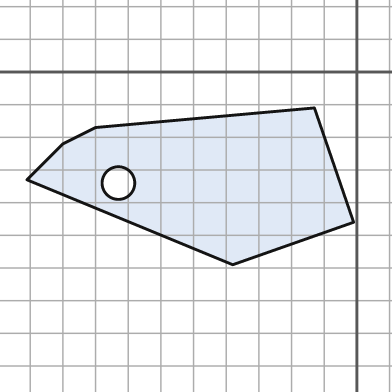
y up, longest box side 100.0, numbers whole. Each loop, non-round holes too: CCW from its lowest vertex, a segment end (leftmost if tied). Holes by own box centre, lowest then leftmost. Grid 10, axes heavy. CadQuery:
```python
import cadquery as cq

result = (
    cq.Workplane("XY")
    .moveTo(-38.0, -59.0)
    .lineTo(-1.0, -46.0)
    .lineTo(-13.0, -11.0)
    .lineTo(-80.0, -17.0)
    .lineTo(-90.0, -22.0)
    .lineTo(-101.0, -33.0)
    .close()
    .moveTo(-73.0, -34.0)
    .circle(5.0)
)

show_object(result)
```